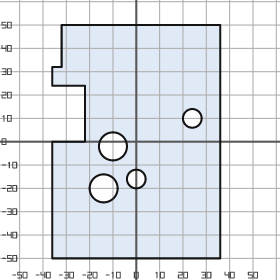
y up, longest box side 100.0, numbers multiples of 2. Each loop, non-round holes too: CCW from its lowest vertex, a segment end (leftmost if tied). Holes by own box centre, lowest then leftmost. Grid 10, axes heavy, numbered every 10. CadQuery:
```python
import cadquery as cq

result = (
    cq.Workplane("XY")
    .moveTo(-36.0, -50.0)
    .lineTo(36.0, -50.0)
    .lineTo(36.0, 50.0)
    .lineTo(-32.0, 50.0)
    .lineTo(-32.0, 32.0)
    .lineTo(-36.0, 32.0)
    .lineTo(-36.0, 24.0)
    .lineTo(-22.0, 24.0)
    .lineTo(-22.0, 0.0)
    .lineTo(-36.0, 0.0)
    .close()
    .moveTo(-14.0, -20.0)
    .circle(6.0)
    .moveTo(0.0, -16.0)
    .circle(4.0)
    .moveTo(-10.0, -2.0)
    .circle(6.0)
    .moveTo(24.0, 10.0)
    .circle(4.0)
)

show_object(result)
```